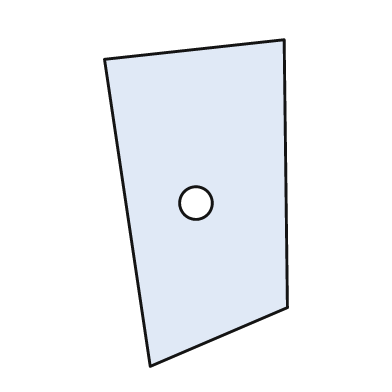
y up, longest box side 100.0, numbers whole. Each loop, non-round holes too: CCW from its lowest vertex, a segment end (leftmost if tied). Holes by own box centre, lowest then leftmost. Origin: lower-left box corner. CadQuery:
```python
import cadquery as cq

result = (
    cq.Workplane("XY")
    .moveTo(14.0, 0.0)
    .lineTo(56.0, 18.0)
    .lineTo(55.0, 100.0)
    .lineTo(0.0, 94.0)
    .close()
    .moveTo(28.0, 50.0)
    .circle(5.0)
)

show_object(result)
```